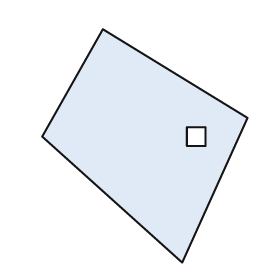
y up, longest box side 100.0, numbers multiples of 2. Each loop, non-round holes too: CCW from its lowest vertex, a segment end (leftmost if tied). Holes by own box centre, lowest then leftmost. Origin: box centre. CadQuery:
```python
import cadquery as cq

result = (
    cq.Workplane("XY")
    .moveTo(16.0, -50.0)
    .lineTo(44.0, 12.0)
    .lineTo(-18.0, 50.0)
    .lineTo(-44.0, 4.0)
    .close()
    .moveTo(18.0, 0.0)
    .lineTo(26.0, 0.0)
    .lineTo(26.0, 8.0)
    .lineTo(18.0, 8.0)
    .close()
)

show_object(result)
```